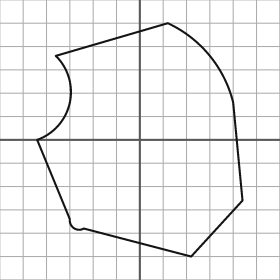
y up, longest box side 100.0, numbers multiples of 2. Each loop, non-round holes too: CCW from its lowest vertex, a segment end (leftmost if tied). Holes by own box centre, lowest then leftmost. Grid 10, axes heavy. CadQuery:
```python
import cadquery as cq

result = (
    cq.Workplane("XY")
    .moveTo(22.0, -50.0)
    .lineTo(44.0, -26.0)
    .lineTo(40.0, 16.0)
    .threePointArc((30.0, 36.0), (12.0, 50.0))
    .lineTo(-36.0, 36.0)
    .threePointArc((-30.0, 16.0), (-44.0, 0.0))
    .lineTo(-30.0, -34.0)
    .threePointArc((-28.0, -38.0), (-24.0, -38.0))
    .close()
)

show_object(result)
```